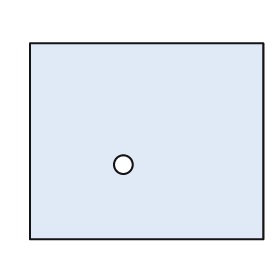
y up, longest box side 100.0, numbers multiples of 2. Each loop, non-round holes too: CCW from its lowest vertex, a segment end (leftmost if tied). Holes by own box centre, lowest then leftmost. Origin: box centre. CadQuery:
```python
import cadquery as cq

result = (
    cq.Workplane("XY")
    .moveTo(-50.0, -42.0)
    .lineTo(50.0, -42.0)
    .lineTo(50.0, 42.0)
    .lineTo(-50.0, 42.0)
    .close()
    .moveTo(-10.0, -10.0)
    .circle(4.0)
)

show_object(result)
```